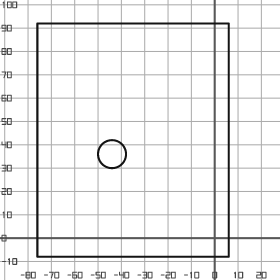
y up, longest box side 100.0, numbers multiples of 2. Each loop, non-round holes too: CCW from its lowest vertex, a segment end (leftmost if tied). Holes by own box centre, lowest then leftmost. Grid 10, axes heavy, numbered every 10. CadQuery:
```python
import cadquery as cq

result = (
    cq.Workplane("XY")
    .moveTo(-76.0, -8.0)
    .lineTo(6.0, -8.0)
    .lineTo(6.0, 92.0)
    .lineTo(-76.0, 92.0)
    .close()
    .moveTo(-44.0, 36.0)
    .circle(6.0)
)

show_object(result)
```